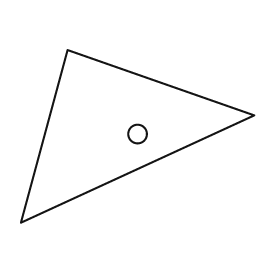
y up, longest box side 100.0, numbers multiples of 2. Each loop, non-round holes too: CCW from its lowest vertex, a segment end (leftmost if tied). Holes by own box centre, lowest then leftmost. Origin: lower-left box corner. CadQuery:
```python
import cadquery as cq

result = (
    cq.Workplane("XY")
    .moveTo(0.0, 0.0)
    .lineTo(100.0, 46.0)
    .lineTo(20.0, 74.0)
    .close()
    .moveTo(50.0, 38.0)
    .circle(4.0)
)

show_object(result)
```